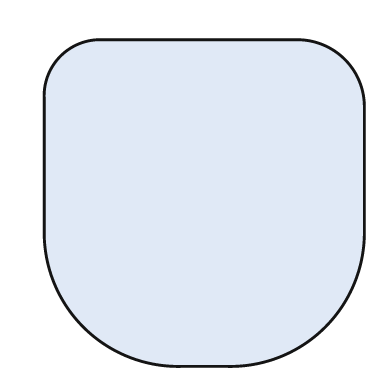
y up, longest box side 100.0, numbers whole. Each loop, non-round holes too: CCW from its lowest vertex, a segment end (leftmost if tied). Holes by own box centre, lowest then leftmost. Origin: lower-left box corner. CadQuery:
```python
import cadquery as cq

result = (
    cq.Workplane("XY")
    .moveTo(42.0, 0.0)
    .lineTo(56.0, 0.0)
    .threePointArc((86.0, 12.0), (98.0, 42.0))
    .lineTo(98.0, 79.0)
    .threePointArc((92.0, 94.0), (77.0, 100.0))
    .lineTo(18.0, 100.0)
    .threePointArc((5.0, 95.0), (0.0, 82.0))
    .lineTo(0.0, 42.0)
    .threePointArc((12.0, 12.0), (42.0, 0.0))
    .close()
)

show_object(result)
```